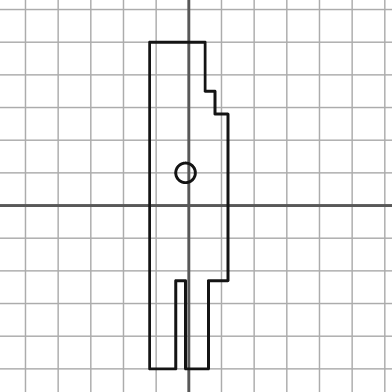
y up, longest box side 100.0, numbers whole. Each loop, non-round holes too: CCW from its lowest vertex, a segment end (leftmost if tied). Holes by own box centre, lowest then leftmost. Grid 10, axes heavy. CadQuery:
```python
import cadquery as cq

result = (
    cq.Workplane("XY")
    .moveTo(-12.0, -50.0)
    .lineTo(-4.0, -50.0)
    .lineTo(-4.0, -23.0)
    .lineTo(-1.0, -23.0)
    .lineTo(-1.0, -50.0)
    .lineTo(6.0, -50.0)
    .lineTo(6.0, -23.0)
    .lineTo(12.0, -23.0)
    .lineTo(12.0, 28.0)
    .lineTo(8.0, 28.0)
    .lineTo(8.0, 35.0)
    .lineTo(5.0, 35.0)
    .lineTo(5.0, 50.0)
    .lineTo(-12.0, 50.0)
    .close()
    .moveTo(-1.0, 10.0)
    .circle(3.0)
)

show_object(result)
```